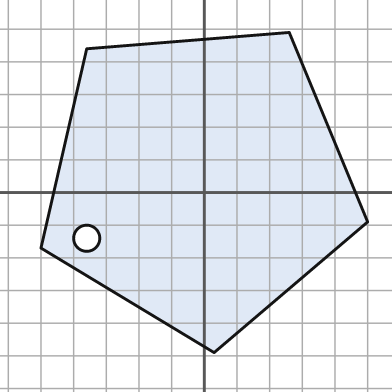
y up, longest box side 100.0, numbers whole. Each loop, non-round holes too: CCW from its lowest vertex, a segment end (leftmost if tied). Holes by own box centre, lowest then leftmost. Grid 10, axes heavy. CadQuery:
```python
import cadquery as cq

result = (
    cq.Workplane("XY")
    .moveTo(3.0, -49.0)
    .lineTo(50.0, -9.0)
    .lineTo(26.0, 49.0)
    .lineTo(-36.0, 44.0)
    .lineTo(-50.0, -17.0)
    .close()
    .moveTo(-36.0, -14.0)
    .circle(4.0)
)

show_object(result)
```